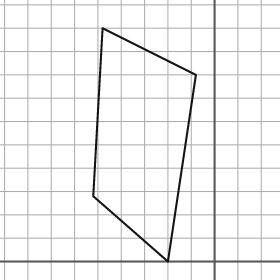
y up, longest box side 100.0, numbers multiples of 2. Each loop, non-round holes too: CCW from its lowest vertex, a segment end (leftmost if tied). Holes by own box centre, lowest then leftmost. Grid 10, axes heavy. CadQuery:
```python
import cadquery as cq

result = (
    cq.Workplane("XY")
    .moveTo(-20.0, 0.0)
    .lineTo(-8.0, 80.0)
    .lineTo(-48.0, 100.0)
    .lineTo(-52.0, 28.0)
    .close()
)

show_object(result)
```